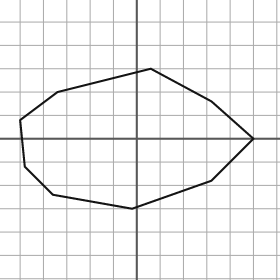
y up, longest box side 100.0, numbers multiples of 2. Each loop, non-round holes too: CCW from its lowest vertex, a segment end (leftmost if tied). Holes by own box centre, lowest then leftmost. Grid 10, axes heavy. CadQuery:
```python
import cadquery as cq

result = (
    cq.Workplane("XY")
    .moveTo(-2.0, -30.0)
    .lineTo(32.0, -18.0)
    .lineTo(50.0, 0.0)
    .lineTo(32.0, 16.0)
    .lineTo(6.0, 30.0)
    .lineTo(-34.0, 20.0)
    .lineTo(-50.0, 8.0)
    .lineTo(-48.0, -12.0)
    .lineTo(-36.0, -24.0)
    .close()
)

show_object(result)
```